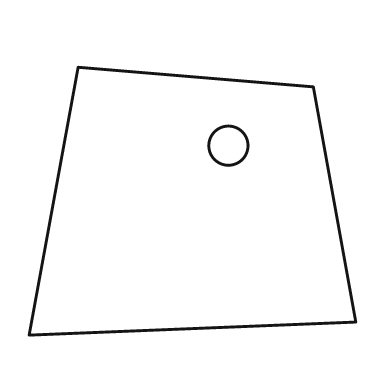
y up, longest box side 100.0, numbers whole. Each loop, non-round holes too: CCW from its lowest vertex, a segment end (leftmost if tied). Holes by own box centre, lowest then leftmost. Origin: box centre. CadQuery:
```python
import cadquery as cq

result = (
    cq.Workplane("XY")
    .moveTo(-50.0, -41.0)
    .lineTo(50.0, -37.0)
    .lineTo(37.0, 35.0)
    .lineTo(-35.0, 41.0)
    .close()
    .moveTo(11.0, 17.0)
    .circle(6.0)
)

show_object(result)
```